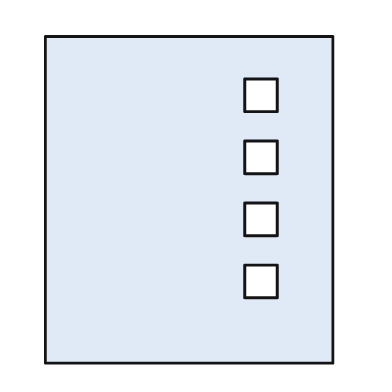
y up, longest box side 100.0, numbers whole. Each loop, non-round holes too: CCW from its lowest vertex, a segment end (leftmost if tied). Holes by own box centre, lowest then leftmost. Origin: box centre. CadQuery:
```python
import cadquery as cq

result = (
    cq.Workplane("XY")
    .moveTo(-44.0, -50.0)
    .lineTo(44.0, -50.0)
    .lineTo(44.0, 50.0)
    .lineTo(-44.0, 50.0)
    .close()
    .moveTo(17.0, -30.0)
    .lineTo(27.0, -30.0)
    .lineTo(27.0, -20.0)
    .lineTo(17.0, -20.0)
    .close()
    .moveTo(17.0, -11.0)
    .lineTo(27.0, -11.0)
    .lineTo(27.0, -1.0)
    .lineTo(17.0, -1.0)
    .close()
    .moveTo(17.0, 8.0)
    .lineTo(27.0, 8.0)
    .lineTo(27.0, 18.0)
    .lineTo(17.0, 18.0)
    .close()
    .moveTo(17.0, 27.0)
    .lineTo(27.0, 27.0)
    .lineTo(27.0, 37.0)
    .lineTo(17.0, 37.0)
    .close()
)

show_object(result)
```